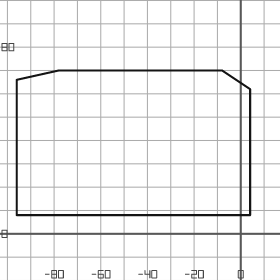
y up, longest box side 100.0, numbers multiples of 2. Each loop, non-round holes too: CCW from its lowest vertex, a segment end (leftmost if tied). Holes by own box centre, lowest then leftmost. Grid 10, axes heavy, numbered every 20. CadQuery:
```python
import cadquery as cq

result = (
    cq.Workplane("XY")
    .moveTo(-96.0, 8.0)
    .lineTo(4.0, 8.0)
    .lineTo(4.0, 62.0)
    .lineTo(-8.0, 70.0)
    .lineTo(-78.0, 70.0)
    .lineTo(-96.0, 66.0)
    .close()
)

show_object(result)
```